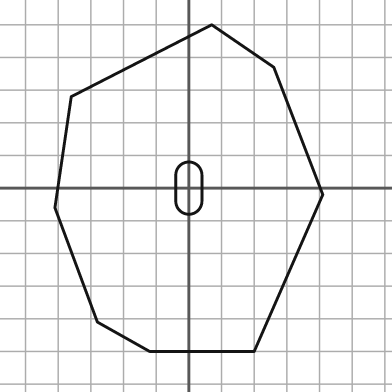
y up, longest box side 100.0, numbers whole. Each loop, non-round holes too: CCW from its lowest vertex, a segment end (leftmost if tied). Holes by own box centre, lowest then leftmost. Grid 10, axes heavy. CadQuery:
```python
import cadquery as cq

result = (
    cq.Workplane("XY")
    .moveTo(-12.0, -50.0)
    .lineTo(20.0, -50.0)
    .lineTo(41.0, -2.0)
    .lineTo(26.0, 37.0)
    .lineTo(7.0, 50.0)
    .lineTo(-36.0, 28.0)
    .lineTo(-41.0, -6.0)
    .lineTo(-28.0, -41.0)
    .close()
    .moveTo(-4.0, -4.0)
    .threePointArc((0.0, -8.0), (4.0, -4.0))
    .lineTo(4.0, 4.0)
    .threePointArc((0.0, 8.0), (-4.0, 4.0))
    .close()
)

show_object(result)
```